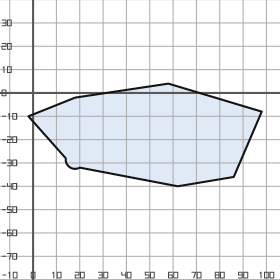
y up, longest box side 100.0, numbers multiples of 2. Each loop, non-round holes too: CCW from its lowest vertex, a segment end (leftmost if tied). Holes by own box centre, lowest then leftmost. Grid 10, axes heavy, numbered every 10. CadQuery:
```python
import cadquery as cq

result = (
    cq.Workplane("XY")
    .moveTo(62.0, -40.0)
    .lineTo(86.0, -36.0)
    .lineTo(98.0, -8.0)
    .lineTo(58.0, 4.0)
    .lineTo(18.0, -2.0)
    .lineTo(-2.0, -10.0)
    .lineTo(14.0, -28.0)
    .threePointArc((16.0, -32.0), (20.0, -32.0))
    .close()
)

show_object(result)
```